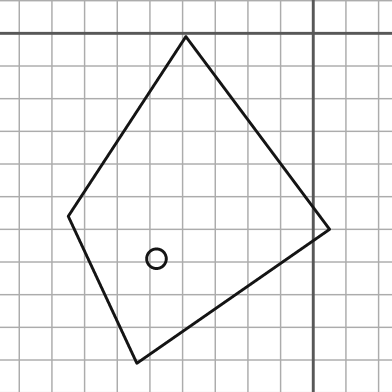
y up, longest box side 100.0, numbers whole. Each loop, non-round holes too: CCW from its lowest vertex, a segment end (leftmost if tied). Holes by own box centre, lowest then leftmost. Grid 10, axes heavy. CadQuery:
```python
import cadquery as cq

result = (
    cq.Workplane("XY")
    .moveTo(-54.0, -101.0)
    .lineTo(5.0, -60.0)
    .lineTo(-39.0, -1.0)
    .lineTo(-75.0, -56.0)
    .close()
    .moveTo(-48.0, -69.0)
    .circle(3.0)
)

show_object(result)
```